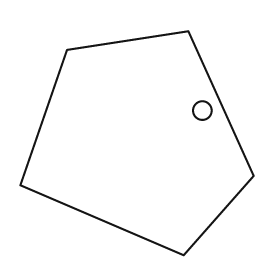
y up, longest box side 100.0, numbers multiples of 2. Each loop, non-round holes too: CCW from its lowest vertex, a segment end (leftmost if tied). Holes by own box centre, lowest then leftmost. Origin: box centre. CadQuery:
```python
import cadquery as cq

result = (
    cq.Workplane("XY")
    .moveTo(20.0, -48.0)
    .lineTo(50.0, -14.0)
    .lineTo(22.0, 48.0)
    .lineTo(-30.0, 40.0)
    .lineTo(-50.0, -18.0)
    .close()
    .moveTo(28.0, 14.0)
    .circle(4.0)
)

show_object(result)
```